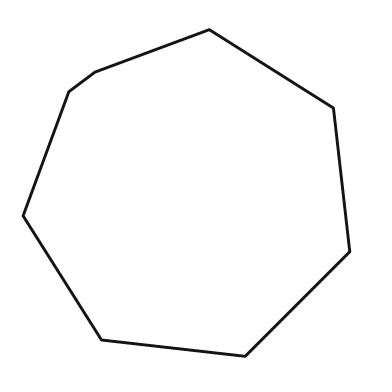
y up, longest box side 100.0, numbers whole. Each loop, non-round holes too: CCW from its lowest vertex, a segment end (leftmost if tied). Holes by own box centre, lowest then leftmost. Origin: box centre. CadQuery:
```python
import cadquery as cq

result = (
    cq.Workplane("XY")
    .moveTo(18.0, -50.0)
    .lineTo(50.0, -18.0)
    .lineTo(45.0, 26.0)
    .lineTo(7.0, 50.0)
    .lineTo(-28.0, 37.0)
    .lineTo(-36.0, 31.0)
    .lineTo(-50.0, -7.0)
    .lineTo(-26.0, -45.0)
    .close()
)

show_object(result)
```